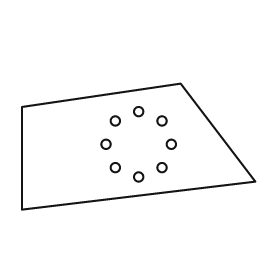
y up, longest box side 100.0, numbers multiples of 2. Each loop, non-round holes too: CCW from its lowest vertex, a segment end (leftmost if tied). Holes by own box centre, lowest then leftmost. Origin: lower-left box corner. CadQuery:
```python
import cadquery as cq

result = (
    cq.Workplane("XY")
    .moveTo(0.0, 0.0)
    .lineTo(100.0, 12.0)
    .lineTo(68.0, 54.0)
    .lineTo(0.0, 44.0)
    .close()
    .moveTo(50.0, 14.0)
    .circle(2.0)
    .moveTo(40.0, 18.0)
    .circle(2.0)
    .moveTo(60.0, 18.0)
    .circle(2.0)
    .moveTo(36.0, 28.0)
    .circle(2.0)
    .moveTo(64.0, 28.0)
    .circle(2.0)
    .moveTo(40.0, 38.0)
    .circle(2.0)
    .moveTo(60.0, 38.0)
    .circle(2.0)
    .moveTo(50.0, 42.0)
    .circle(2.0)
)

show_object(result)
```